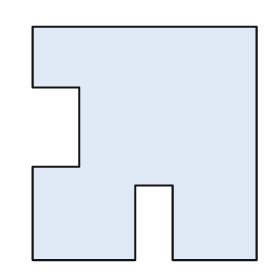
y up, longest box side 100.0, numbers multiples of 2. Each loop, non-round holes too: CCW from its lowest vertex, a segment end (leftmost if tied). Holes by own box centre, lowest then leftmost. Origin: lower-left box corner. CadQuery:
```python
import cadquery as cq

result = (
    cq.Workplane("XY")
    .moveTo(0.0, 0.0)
    .lineTo(44.0, 0.0)
    .lineTo(44.0, 32.0)
    .lineTo(60.0, 32.0)
    .lineTo(60.0, 0.0)
    .lineTo(96.0, 0.0)
    .lineTo(96.0, 100.0)
    .lineTo(0.0, 100.0)
    .lineTo(0.0, 74.0)
    .lineTo(20.0, 74.0)
    .lineTo(20.0, 40.0)
    .lineTo(0.0, 40.0)
    .close()
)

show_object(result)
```